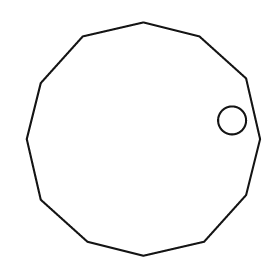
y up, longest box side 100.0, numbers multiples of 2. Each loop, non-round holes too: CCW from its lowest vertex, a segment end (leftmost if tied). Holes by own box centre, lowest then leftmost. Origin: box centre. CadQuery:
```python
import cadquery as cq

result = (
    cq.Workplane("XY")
    .moveTo(0.0, -50.0)
    .lineTo(26.0, -44.0)
    .lineTo(44.0, -24.0)
    .lineTo(50.0, 0.0)
    .lineTo(44.0, 26.0)
    .lineTo(24.0, 44.0)
    .lineTo(0.0, 50.0)
    .lineTo(-26.0, 44.0)
    .lineTo(-44.0, 24.0)
    .lineTo(-50.0, 0.0)
    .lineTo(-44.0, -26.0)
    .lineTo(-24.0, -44.0)
    .close()
    .moveTo(38.0, 8.0)
    .circle(6.0)
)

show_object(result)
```